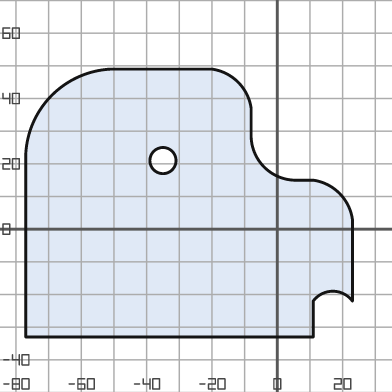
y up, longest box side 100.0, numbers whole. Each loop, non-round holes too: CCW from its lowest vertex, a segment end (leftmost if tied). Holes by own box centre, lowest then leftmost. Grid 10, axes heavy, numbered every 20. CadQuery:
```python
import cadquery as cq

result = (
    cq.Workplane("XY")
    .moveTo(-77.0, -33.0)
    .lineTo(11.0, -33.0)
    .lineTo(11.0, -22.0)
    .threePointArc((17.0, -19.0), (23.0, -22.0))
    .lineTo(23.0, 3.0)
    .threePointArc((19.0, 11.0), (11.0, 15.0))
    .lineTo(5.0, 15.0)
    .threePointArc((-4.0, 19.0), (-8.0, 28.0))
    .lineTo(-8.0, 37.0)
    .threePointArc((-12.0, 45.0), (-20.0, 49.0))
    .lineTo(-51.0, 49.0)
    .threePointArc((-69.0, 41.0), (-77.0, 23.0))
    .close()
    .moveTo(-35.0, 21.0)
    .circle(4.0)
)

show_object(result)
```